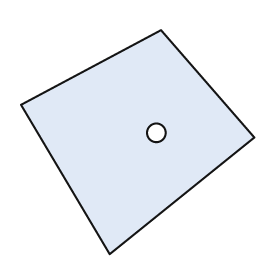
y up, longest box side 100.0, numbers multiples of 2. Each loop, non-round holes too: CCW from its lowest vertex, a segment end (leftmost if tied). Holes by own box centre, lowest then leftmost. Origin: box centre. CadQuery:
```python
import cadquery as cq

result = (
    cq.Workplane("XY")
    .moveTo(-12.0, -48.0)
    .lineTo(50.0, 2.0)
    .lineTo(10.0, 48.0)
    .lineTo(-50.0, 16.0)
    .close()
    .moveTo(8.0, 4.0)
    .circle(4.0)
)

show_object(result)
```